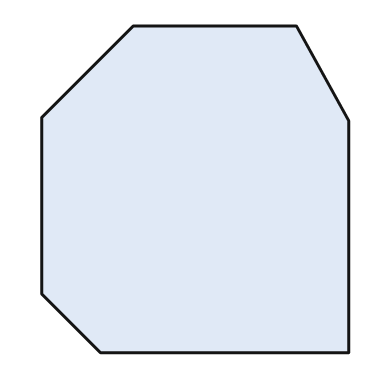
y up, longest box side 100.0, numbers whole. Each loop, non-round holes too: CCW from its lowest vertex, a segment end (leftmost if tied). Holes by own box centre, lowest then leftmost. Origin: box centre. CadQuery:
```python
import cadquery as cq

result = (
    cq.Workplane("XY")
    .moveTo(-29.0, -50.0)
    .lineTo(47.0, -50.0)
    .lineTo(47.0, 21.0)
    .lineTo(31.0, 50.0)
    .lineTo(-19.0, 50.0)
    .lineTo(-47.0, 22.0)
    .lineTo(-47.0, -32.0)
    .close()
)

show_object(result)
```